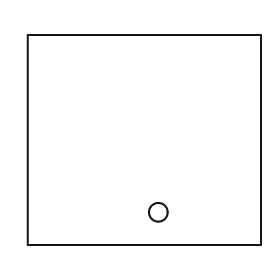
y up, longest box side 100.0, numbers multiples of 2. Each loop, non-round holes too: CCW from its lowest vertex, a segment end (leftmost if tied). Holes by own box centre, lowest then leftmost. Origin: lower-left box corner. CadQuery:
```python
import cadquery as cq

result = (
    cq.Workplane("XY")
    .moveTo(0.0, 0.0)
    .lineTo(100.0, 0.0)
    .lineTo(100.0, 90.0)
    .lineTo(0.0, 90.0)
    .close()
    .moveTo(56.0, 14.0)
    .circle(4.0)
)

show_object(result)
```